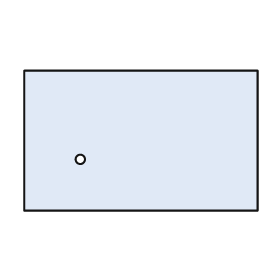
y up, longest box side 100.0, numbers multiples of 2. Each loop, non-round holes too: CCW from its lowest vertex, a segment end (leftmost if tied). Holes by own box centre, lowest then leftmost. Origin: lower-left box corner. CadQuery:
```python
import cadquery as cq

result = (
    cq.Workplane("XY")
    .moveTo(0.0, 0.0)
    .lineTo(100.0, 0.0)
    .lineTo(100.0, 60.0)
    .lineTo(0.0, 60.0)
    .close()
    .moveTo(24.0, 22.0)
    .circle(2.0)
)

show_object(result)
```